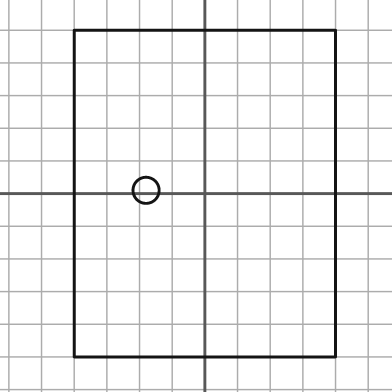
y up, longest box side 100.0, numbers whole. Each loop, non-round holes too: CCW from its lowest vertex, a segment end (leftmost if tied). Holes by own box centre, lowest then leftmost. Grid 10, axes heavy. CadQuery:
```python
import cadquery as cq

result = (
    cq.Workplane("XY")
    .moveTo(-40.0, -50.0)
    .lineTo(40.0, -50.0)
    .lineTo(40.0, 50.0)
    .lineTo(-40.0, 50.0)
    .close()
    .moveTo(-18.0, 1.0)
    .circle(4.0)
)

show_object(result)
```